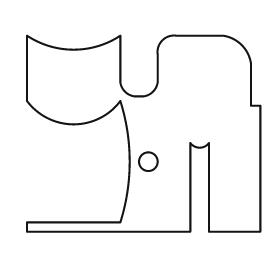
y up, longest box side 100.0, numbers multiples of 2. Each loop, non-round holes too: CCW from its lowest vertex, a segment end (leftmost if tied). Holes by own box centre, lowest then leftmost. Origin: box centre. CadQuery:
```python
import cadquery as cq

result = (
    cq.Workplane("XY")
    .moveTo(-50.0, -42.0)
    .lineTo(20.0, -42.0)
    .lineTo(20.0, -4.0)
    .threePointArc((24.0, -6.0), (28.0, -4.0))
    .lineTo(28.0, -42.0)
    .lineTo(50.0, -42.0)
    .lineTo(50.0, 12.0)
    .lineTo(46.0, 12.0)
    .lineTo(46.0, 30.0)
    .threePointArc((42.0, 38.0), (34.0, 42.0))
    .lineTo(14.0, 42.0)
    .threePointArc((8.0, 40.0), (6.0, 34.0))
    .lineTo(6.0, 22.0)
    .threePointArc((4.0, 18.0), (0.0, 16.0))
    .lineTo(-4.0, 16.0)
    .threePointArc((-8.0, 18.0), (-10.0, 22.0))
    .lineTo(-10.0, 42.0)
    .threePointArc((-30.0, 36.0), (-50.0, 42.0))
    .lineTo(-50.0, 14.0)
    .threePointArc((-30.0, 4.0), (-10.0, 14.0))
    .threePointArc((-6.0, -12.0), (-10.0, -38.0))
    .lineTo(-50.0, -38.0)
    .close()
    .moveTo(2.0, -12.0)
    .circle(4.0)
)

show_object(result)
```